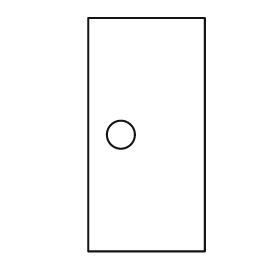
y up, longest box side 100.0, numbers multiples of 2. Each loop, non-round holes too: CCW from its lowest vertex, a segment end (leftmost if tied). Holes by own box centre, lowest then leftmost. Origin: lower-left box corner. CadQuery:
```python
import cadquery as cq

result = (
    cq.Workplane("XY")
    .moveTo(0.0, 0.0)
    .lineTo(50.0, 0.0)
    .lineTo(50.0, 100.0)
    .lineTo(0.0, 100.0)
    .close()
    .moveTo(14.0, 50.0)
    .circle(6.0)
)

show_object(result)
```